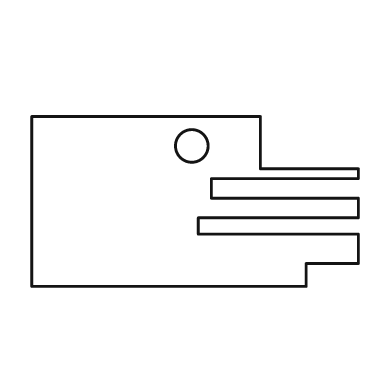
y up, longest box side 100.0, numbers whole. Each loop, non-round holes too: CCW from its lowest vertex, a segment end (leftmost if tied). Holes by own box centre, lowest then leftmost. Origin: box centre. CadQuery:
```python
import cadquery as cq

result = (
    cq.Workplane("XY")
    .moveTo(-50.0, -26.0)
    .lineTo(34.0, -26.0)
    .lineTo(34.0, -19.0)
    .lineTo(50.0, -19.0)
    .lineTo(50.0, -10.0)
    .lineTo(1.0, -10.0)
    .lineTo(1.0, -5.0)
    .lineTo(50.0, -5.0)
    .lineTo(50.0, 1.0)
    .lineTo(5.0, 1.0)
    .lineTo(5.0, 7.0)
    .lineTo(50.0, 7.0)
    .lineTo(50.0, 10.0)
    .lineTo(20.0, 10.0)
    .lineTo(20.0, 26.0)
    .lineTo(-50.0, 26.0)
    .close()
    .moveTo(-1.0, 17.0)
    .circle(5.0)
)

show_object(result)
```